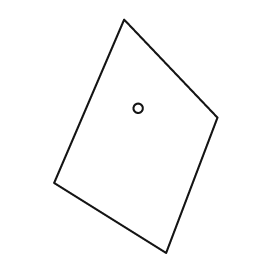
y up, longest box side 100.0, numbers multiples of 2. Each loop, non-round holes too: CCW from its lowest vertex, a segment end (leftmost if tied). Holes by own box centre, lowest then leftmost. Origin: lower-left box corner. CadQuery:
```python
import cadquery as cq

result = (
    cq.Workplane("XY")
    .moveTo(48.0, 0.0)
    .lineTo(70.0, 58.0)
    .lineTo(30.0, 100.0)
    .lineTo(0.0, 30.0)
    .close()
    .moveTo(36.0, 62.0)
    .circle(2.0)
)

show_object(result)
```